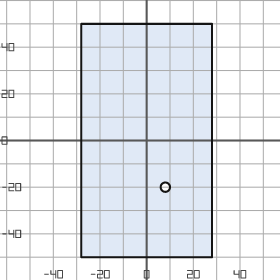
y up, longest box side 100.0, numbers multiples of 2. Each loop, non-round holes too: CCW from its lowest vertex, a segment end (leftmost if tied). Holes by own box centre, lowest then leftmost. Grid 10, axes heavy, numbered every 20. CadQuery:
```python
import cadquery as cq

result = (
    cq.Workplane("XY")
    .moveTo(-28.0, -50.0)
    .lineTo(28.0, -50.0)
    .lineTo(28.0, 50.0)
    .lineTo(-28.0, 50.0)
    .close()
    .moveTo(8.0, -20.0)
    .circle(2.0)
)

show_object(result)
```